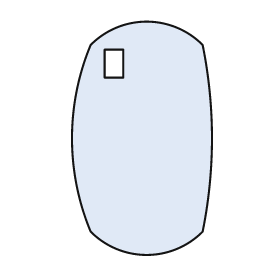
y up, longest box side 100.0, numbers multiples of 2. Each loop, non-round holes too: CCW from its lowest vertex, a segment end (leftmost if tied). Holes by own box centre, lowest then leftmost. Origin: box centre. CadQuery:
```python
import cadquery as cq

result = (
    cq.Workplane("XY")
    .moveTo(-22.0, -40.0)
    .threePointArc((2.0, -50.0), (26.0, -40.0))
    .threePointArc((30.0, 0.0), (26.0, 40.0))
    .threePointArc((2.0, 50.0), (-22.0, 40.0))
    .threePointArc((-30.0, 0.0), (-22.0, -40.0))
    .close()
    .moveTo(-16.0, 26.0)
    .lineTo(-8.0, 26.0)
    .lineTo(-8.0, 38.0)
    .lineTo(-16.0, 38.0)
    .close()
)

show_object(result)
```